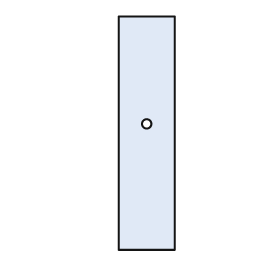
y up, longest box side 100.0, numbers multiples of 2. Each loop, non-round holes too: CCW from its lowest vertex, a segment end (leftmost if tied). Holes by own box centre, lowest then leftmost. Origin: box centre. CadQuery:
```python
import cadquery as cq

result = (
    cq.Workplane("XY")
    .moveTo(-12.0, -50.0)
    .lineTo(12.0, -50.0)
    .lineTo(12.0, 50.0)
    .lineTo(-12.0, 50.0)
    .close()
    .moveTo(0.0, 4.0)
    .circle(2.0)
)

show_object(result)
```